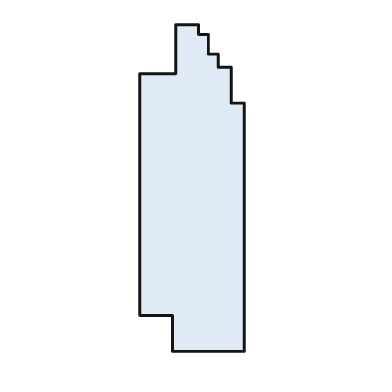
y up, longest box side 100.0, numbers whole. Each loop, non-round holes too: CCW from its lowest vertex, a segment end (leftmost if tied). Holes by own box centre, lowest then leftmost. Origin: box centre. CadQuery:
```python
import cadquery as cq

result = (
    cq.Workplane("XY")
    .moveTo(-6.0, -50.0)
    .lineTo(16.0, -50.0)
    .lineTo(16.0, 26.0)
    .lineTo(12.0, 26.0)
    .lineTo(12.0, 37.0)
    .lineTo(8.0, 37.0)
    .lineTo(8.0, 41.0)
    .lineTo(5.0, 41.0)
    .lineTo(5.0, 47.0)
    .lineTo(2.0, 47.0)
    .lineTo(2.0, 50.0)
    .lineTo(-5.0, 50.0)
    .lineTo(-5.0, 35.0)
    .lineTo(-16.0, 35.0)
    .lineTo(-16.0, -39.0)
    .lineTo(-6.0, -39.0)
    .close()
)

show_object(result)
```